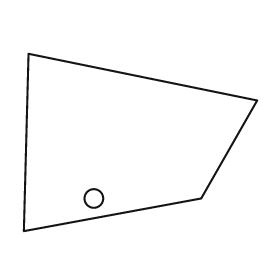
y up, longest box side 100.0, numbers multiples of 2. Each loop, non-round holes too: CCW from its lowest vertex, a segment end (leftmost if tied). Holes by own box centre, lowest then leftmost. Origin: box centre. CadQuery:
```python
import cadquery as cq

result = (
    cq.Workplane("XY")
    .moveTo(-50.0, -38.0)
    .lineTo(26.0, -24.0)
    .lineTo(50.0, 18.0)
    .lineTo(-48.0, 38.0)
    .close()
    .moveTo(-20.0, -24.0)
    .circle(4.0)
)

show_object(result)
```